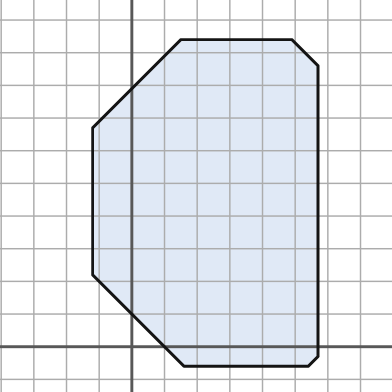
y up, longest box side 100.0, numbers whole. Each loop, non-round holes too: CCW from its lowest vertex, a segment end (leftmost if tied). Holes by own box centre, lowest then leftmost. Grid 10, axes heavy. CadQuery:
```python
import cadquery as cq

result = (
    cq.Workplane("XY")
    .moveTo(16.0, -6.0)
    .lineTo(54.0, -6.0)
    .lineTo(57.0, -3.0)
    .lineTo(57.0, 86.0)
    .lineTo(49.0, 94.0)
    .lineTo(15.0, 94.0)
    .lineTo(-12.0, 67.0)
    .lineTo(-12.0, 22.0)
    .close()
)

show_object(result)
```